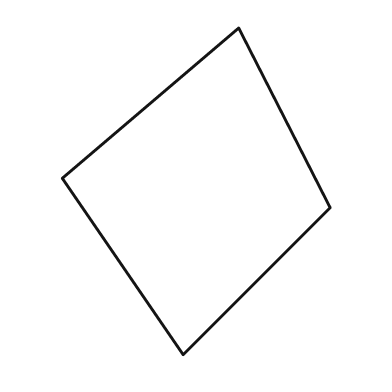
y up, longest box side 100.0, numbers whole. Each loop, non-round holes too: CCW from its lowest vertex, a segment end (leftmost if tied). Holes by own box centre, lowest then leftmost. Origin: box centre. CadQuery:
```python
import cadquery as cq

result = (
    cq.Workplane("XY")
    .moveTo(-4.0, -50.0)
    .lineTo(41.0, -5.0)
    .lineTo(13.0, 50.0)
    .lineTo(-41.0, 4.0)
    .close()
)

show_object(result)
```